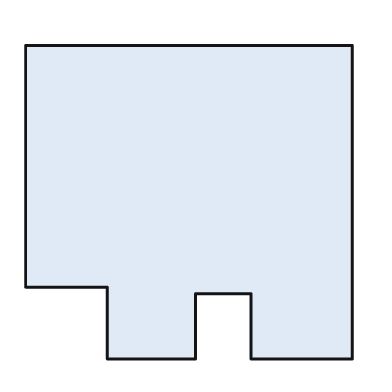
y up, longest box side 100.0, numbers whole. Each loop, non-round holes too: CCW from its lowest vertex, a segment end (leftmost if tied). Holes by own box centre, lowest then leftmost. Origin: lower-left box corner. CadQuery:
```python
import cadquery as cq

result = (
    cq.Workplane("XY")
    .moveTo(25.0, 0.0)
    .lineTo(52.0, 0.0)
    .lineTo(52.0, 20.0)
    .lineTo(69.0, 20.0)
    .lineTo(69.0, 0.0)
    .lineTo(100.0, 0.0)
    .lineTo(100.0, 96.0)
    .lineTo(0.0, 96.0)
    .lineTo(0.0, 22.0)
    .lineTo(25.0, 22.0)
    .close()
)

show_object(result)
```